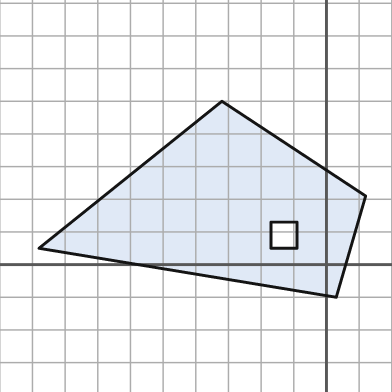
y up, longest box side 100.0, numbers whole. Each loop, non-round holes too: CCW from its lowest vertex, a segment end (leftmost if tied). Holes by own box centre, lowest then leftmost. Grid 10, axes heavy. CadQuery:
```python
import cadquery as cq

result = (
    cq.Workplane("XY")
    .moveTo(3.0, -10.0)
    .lineTo(12.0, 21.0)
    .lineTo(-32.0, 50.0)
    .lineTo(-88.0, 5.0)
    .close()
    .moveTo(-17.0, 5.0)
    .lineTo(-9.0, 5.0)
    .lineTo(-9.0, 13.0)
    .lineTo(-17.0, 13.0)
    .close()
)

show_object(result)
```